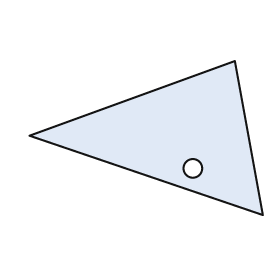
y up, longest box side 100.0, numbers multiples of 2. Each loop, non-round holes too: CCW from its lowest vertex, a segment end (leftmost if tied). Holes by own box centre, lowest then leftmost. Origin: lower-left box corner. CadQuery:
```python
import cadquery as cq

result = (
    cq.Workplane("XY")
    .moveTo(100.0, 0.0)
    .lineTo(88.0, 66.0)
    .lineTo(0.0, 34.0)
    .close()
    .moveTo(70.0, 20.0)
    .circle(4.0)
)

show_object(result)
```